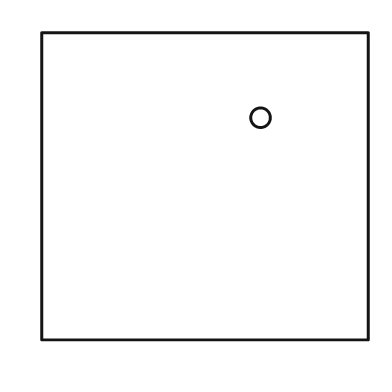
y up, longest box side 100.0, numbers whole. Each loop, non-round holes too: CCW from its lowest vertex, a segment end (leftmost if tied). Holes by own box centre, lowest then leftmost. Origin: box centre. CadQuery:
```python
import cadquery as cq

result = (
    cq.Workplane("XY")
    .moveTo(-50.0, -47.0)
    .lineTo(50.0, -47.0)
    .lineTo(50.0, 47.0)
    .lineTo(-50.0, 47.0)
    .close()
    .moveTo(17.0, 21.0)
    .circle(3.0)
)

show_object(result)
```